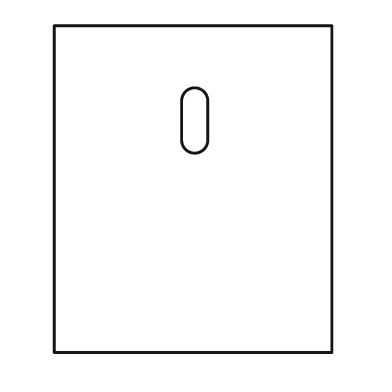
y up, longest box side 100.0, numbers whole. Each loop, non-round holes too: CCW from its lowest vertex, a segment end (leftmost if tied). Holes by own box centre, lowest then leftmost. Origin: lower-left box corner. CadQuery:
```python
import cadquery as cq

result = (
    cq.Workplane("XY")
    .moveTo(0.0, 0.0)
    .lineTo(85.0, 0.0)
    .lineTo(85.0, 100.0)
    .lineTo(0.0, 100.0)
    .close()
    .moveTo(39.0, 65.0)
    .threePointArc((43.0, 61.0), (47.0, 65.0))
    .lineTo(47.0, 77.0)
    .threePointArc((43.0, 81.0), (39.0, 77.0))
    .close()
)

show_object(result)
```